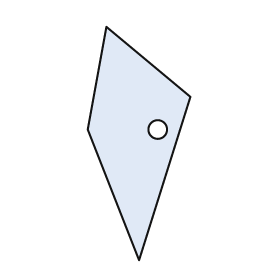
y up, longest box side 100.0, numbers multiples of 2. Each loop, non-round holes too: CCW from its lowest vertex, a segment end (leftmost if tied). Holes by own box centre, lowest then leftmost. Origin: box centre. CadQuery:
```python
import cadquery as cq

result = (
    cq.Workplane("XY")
    .moveTo(0.0, -50.0)
    .lineTo(22.0, 20.0)
    .lineTo(-14.0, 50.0)
    .lineTo(-22.0, 6.0)
    .close()
    .moveTo(8.0, 6.0)
    .circle(4.0)
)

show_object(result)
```